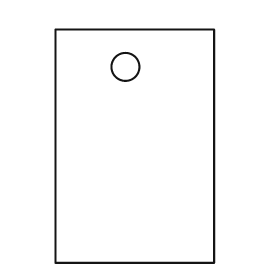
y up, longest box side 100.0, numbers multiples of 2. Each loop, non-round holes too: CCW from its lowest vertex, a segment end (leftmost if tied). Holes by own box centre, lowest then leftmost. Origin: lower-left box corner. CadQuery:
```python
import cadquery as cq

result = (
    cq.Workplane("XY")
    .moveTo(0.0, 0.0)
    .lineTo(68.0, 0.0)
    .lineTo(68.0, 100.0)
    .lineTo(0.0, 100.0)
    .close()
    .moveTo(30.0, 84.0)
    .circle(6.0)
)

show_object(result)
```